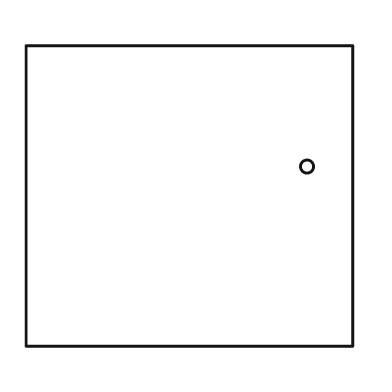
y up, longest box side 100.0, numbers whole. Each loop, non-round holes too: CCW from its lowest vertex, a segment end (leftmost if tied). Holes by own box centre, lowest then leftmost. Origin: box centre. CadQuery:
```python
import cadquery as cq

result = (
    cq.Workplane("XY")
    .moveTo(-50.0, -46.0)
    .lineTo(50.0, -46.0)
    .lineTo(50.0, 46.0)
    .lineTo(-50.0, 46.0)
    .close()
    .moveTo(36.0, 9.0)
    .circle(2.0)
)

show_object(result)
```